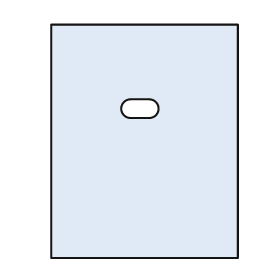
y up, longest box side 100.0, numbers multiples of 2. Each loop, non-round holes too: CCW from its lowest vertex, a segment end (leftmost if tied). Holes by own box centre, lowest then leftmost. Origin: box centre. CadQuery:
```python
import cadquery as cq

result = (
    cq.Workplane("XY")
    .moveTo(-40.0, -50.0)
    .lineTo(40.0, -50.0)
    .lineTo(40.0, 50.0)
    .lineTo(-40.0, 50.0)
    .close()
    .moveTo(-6.0, 10.0)
    .lineTo(2.0, 10.0)
    .threePointArc((6.0, 14.0), (2.0, 18.0))
    .lineTo(-6.0, 18.0)
    .threePointArc((-10.0, 14.0), (-6.0, 10.0))
    .close()
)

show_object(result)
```